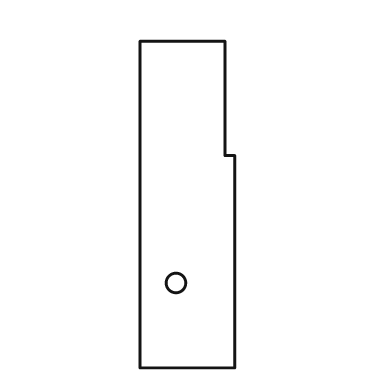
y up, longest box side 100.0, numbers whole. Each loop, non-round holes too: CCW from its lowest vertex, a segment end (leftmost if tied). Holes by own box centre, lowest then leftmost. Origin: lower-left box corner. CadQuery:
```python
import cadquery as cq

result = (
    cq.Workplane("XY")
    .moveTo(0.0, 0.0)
    .lineTo(29.0, 0.0)
    .lineTo(29.0, 65.0)
    .lineTo(26.0, 65.0)
    .lineTo(26.0, 100.0)
    .lineTo(0.0, 100.0)
    .close()
    .moveTo(11.0, 26.0)
    .circle(3.0)
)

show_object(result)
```